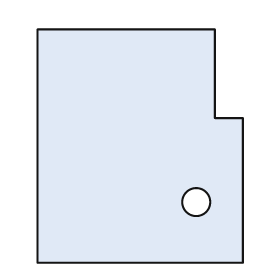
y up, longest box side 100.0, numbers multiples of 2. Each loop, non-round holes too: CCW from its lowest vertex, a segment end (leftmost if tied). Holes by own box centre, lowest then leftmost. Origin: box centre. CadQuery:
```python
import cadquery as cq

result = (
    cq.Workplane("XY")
    .moveTo(-44.0, -50.0)
    .lineTo(44.0, -50.0)
    .lineTo(44.0, 12.0)
    .lineTo(32.0, 12.0)
    .lineTo(32.0, 50.0)
    .lineTo(-44.0, 50.0)
    .close()
    .moveTo(24.0, -24.0)
    .circle(6.0)
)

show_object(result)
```